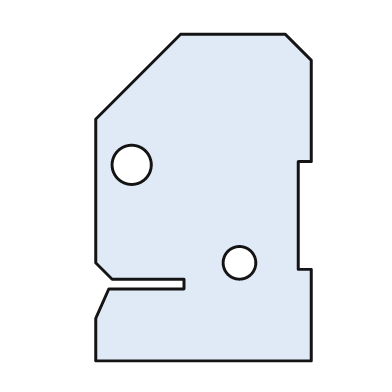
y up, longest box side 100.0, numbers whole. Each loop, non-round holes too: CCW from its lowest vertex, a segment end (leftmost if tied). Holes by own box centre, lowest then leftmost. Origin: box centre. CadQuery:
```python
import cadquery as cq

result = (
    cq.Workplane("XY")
    .moveTo(-33.0, -50.0)
    .lineTo(33.0, -50.0)
    .lineTo(33.0, -22.0)
    .lineTo(29.0, -22.0)
    .lineTo(29.0, 11.0)
    .lineTo(33.0, 11.0)
    .lineTo(33.0, 42.0)
    .lineTo(25.0, 50.0)
    .lineTo(-7.0, 50.0)
    .lineTo(-33.0, 24.0)
    .lineTo(-33.0, -20.0)
    .lineTo(-28.0, -25.0)
    .lineTo(-6.0, -25.0)
    .lineTo(-6.0, -28.0)
    .lineTo(-29.0, -28.0)
    .lineTo(-33.0, -37.0)
    .close()
    .moveTo(11.0, -20.0)
    .circle(5.0)
    .moveTo(-22.0, 10.0)
    .circle(6.0)
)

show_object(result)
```